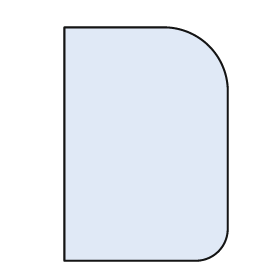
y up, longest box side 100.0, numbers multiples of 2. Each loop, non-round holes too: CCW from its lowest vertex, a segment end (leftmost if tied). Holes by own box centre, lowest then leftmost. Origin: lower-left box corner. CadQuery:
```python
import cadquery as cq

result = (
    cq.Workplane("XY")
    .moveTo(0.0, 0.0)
    .lineTo(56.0, 0.0)
    .threePointArc((66.0, 4.0), (70.0, 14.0))
    .lineTo(70.0, 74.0)
    .threePointArc((62.0, 92.0), (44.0, 100.0))
    .lineTo(0.0, 100.0)
    .close()
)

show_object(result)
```